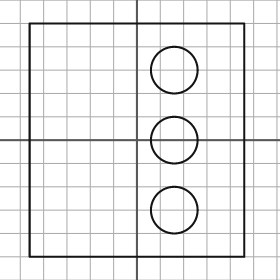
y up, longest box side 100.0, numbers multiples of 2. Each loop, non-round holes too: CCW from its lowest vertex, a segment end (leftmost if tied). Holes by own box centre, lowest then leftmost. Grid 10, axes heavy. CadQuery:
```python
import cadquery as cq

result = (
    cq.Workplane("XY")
    .moveTo(-46.0, -50.0)
    .lineTo(46.0, -50.0)
    .lineTo(46.0, 50.0)
    .lineTo(-46.0, 50.0)
    .close()
    .moveTo(16.0, -30.0)
    .circle(10.0)
    .moveTo(16.0, 0.0)
    .circle(10.0)
    .moveTo(16.0, 30.0)
    .circle(10.0)
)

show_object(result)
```